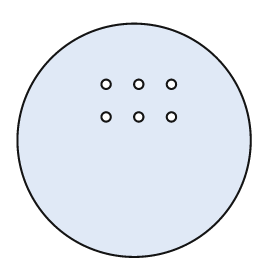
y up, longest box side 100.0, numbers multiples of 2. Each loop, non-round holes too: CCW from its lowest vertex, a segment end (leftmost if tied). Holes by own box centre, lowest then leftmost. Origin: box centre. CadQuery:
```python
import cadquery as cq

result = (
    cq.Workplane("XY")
    .moveTo(0.0, 0.0)
    .circle(50.0)
    .moveTo(-12.0, 10.0)
    .circle(2.0)
    .moveTo(2.0, 10.0)
    .circle(2.0)
    .moveTo(16.0, 10.0)
    .circle(2.0)
    .moveTo(-12.0, 24.0)
    .circle(2.0)
    .moveTo(2.0, 24.0)
    .circle(2.0)
    .moveTo(16.0, 24.0)
    .circle(2.0)
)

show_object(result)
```